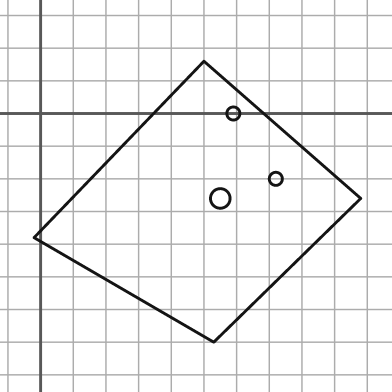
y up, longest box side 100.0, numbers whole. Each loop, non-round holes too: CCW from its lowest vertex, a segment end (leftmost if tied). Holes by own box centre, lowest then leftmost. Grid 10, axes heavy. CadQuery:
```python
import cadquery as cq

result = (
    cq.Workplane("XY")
    .moveTo(53.0, -70.0)
    .lineTo(98.0, -26.0)
    .lineTo(50.0, 16.0)
    .lineTo(-2.0, -38.0)
    .close()
    .moveTo(55.0, -26.0)
    .circle(3.0)
    .moveTo(72.0, -20.0)
    .circle(2.0)
    .moveTo(59.0, 0.0)
    .circle(2.0)
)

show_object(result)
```